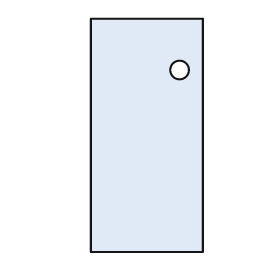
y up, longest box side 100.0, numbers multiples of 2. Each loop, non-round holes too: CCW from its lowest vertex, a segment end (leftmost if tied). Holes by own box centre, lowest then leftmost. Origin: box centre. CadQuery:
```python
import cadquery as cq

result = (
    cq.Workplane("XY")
    .moveTo(-24.0, -50.0)
    .lineTo(24.0, -50.0)
    .lineTo(24.0, 50.0)
    .lineTo(-24.0, 50.0)
    .close()
    .moveTo(14.0, 28.0)
    .circle(4.0)
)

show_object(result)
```